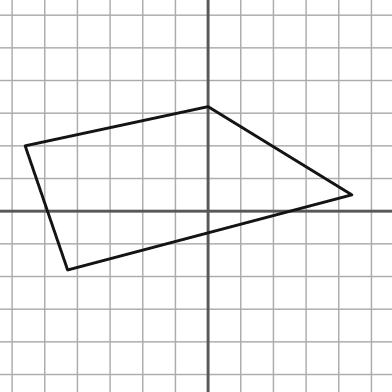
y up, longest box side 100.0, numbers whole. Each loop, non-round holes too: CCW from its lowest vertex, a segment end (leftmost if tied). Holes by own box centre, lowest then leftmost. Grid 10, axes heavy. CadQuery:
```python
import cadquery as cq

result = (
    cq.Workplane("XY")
    .moveTo(-43.0, -18.0)
    .lineTo(44.0, 5.0)
    .lineTo(0.0, 32.0)
    .lineTo(-56.0, 20.0)
    .close()
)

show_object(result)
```